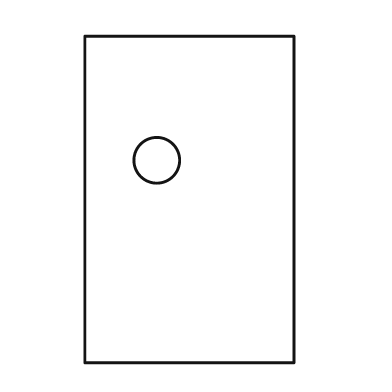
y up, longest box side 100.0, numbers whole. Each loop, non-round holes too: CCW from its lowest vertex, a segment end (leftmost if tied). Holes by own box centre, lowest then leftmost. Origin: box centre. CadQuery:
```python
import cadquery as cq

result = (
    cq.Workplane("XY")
    .moveTo(-32.0, -50.0)
    .lineTo(32.0, -50.0)
    .lineTo(32.0, 50.0)
    .lineTo(-32.0, 50.0)
    .close()
    .moveTo(-10.0, 12.0)
    .circle(7.0)
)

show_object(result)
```